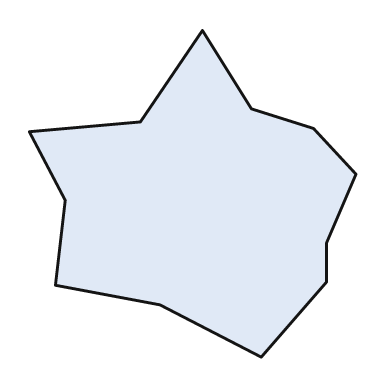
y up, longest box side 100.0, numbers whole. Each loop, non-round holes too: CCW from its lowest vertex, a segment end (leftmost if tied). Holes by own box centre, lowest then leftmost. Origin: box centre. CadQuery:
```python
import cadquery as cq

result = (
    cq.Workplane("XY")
    .moveTo(21.0, -50.0)
    .lineTo(41.0, -27.0)
    .lineTo(41.0, -15.0)
    .lineTo(50.0, 6.0)
    .lineTo(37.0, 20.0)
    .lineTo(18.0, 26.0)
    .lineTo(3.0, 50.0)
    .lineTo(-16.0, 22.0)
    .lineTo(-50.0, 19.0)
    .lineTo(-39.0, -2.0)
    .lineTo(-42.0, -28.0)
    .lineTo(-10.0, -34.0)
    .close()
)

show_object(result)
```